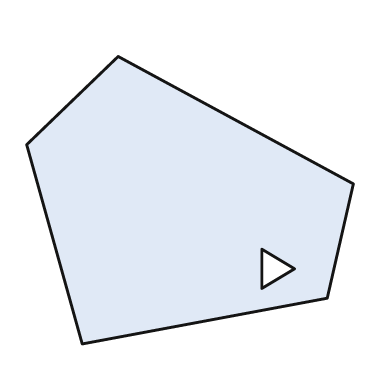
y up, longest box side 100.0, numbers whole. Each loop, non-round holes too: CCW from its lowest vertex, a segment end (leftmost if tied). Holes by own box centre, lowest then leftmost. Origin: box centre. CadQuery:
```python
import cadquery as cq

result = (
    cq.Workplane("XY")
    .moveTo(-33.0, -44.0)
    .lineTo(42.0, -30.0)
    .lineTo(50.0, 5.0)
    .lineTo(-22.0, 44.0)
    .lineTo(-50.0, 17.0)
    .close()
    .moveTo(22.0, -27.0)
    .lineTo(32.0, -21.0)
    .lineTo(22.0, -15.0)
    .close()
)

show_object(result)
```